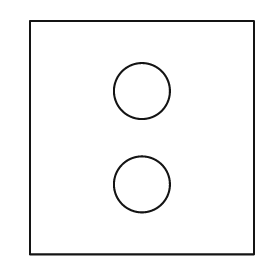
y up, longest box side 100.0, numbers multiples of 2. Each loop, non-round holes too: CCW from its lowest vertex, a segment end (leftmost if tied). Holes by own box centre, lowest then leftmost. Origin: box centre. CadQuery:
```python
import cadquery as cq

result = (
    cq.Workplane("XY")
    .moveTo(-48.0, -50.0)
    .lineTo(48.0, -50.0)
    .lineTo(48.0, 50.0)
    .lineTo(-48.0, 50.0)
    .close()
    .moveTo(0.0, -20.0)
    .circle(12.0)
    .moveTo(0.0, 20.0)
    .circle(12.0)
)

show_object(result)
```